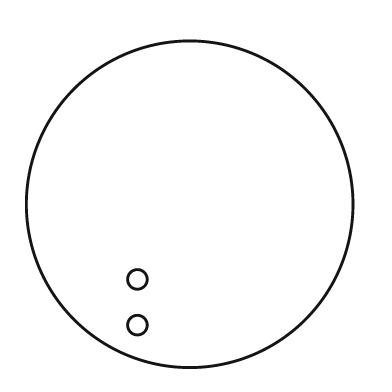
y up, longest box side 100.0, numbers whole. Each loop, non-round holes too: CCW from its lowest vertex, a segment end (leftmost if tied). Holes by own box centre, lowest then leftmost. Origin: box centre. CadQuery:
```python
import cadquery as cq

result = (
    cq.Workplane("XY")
    .moveTo(0.0, 0.0)
    .circle(50.0)
    .moveTo(-16.0, -37.0)
    .circle(3.0)
    .moveTo(-16.0, -23.0)
    .circle(3.0)
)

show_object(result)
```